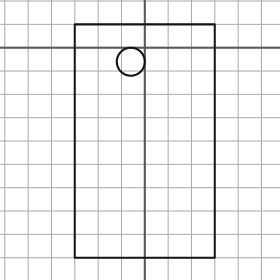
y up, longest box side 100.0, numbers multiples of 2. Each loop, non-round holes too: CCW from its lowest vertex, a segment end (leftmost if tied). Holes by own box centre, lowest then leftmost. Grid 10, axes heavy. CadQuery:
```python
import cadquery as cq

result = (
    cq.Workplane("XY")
    .moveTo(-30.0, -90.0)
    .lineTo(30.0, -90.0)
    .lineTo(30.0, 10.0)
    .lineTo(-30.0, 10.0)
    .close()
    .moveTo(-6.0, -6.0)
    .circle(6.0)
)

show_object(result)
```